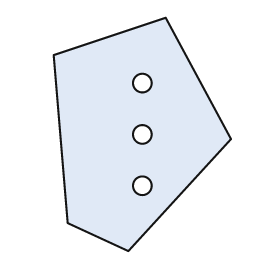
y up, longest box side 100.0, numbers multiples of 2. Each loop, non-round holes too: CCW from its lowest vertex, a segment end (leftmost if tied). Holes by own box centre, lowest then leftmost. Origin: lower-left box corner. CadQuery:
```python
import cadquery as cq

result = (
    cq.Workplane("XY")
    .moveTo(32.0, 0.0)
    .lineTo(76.0, 48.0)
    .lineTo(48.0, 100.0)
    .lineTo(0.0, 84.0)
    .lineTo(6.0, 12.0)
    .close()
    .moveTo(38.0, 28.0)
    .circle(4.0)
    .moveTo(38.0, 50.0)
    .circle(4.0)
    .moveTo(38.0, 72.0)
    .circle(4.0)
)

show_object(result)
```